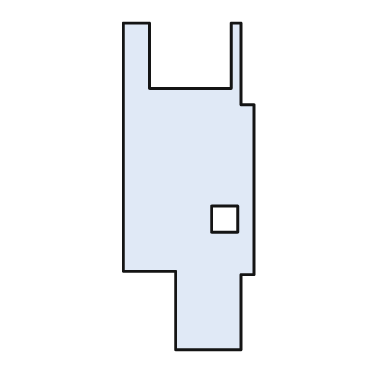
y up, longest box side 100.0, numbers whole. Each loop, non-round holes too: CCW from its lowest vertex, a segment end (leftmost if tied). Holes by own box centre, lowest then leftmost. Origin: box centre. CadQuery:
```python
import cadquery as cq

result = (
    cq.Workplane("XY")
    .moveTo(-4.0, -50.0)
    .lineTo(16.0, -50.0)
    .lineTo(16.0, -27.0)
    .lineTo(20.0, -27.0)
    .lineTo(20.0, 25.0)
    .lineTo(16.0, 25.0)
    .lineTo(16.0, 50.0)
    .lineTo(13.0, 50.0)
    .lineTo(13.0, 30.0)
    .lineTo(-12.0, 30.0)
    .lineTo(-12.0, 50.0)
    .lineTo(-20.0, 50.0)
    .lineTo(-20.0, -26.0)
    .lineTo(-4.0, -26.0)
    .close()
    .moveTo(7.0, -14.0)
    .lineTo(15.0, -14.0)
    .lineTo(15.0, -6.0)
    .lineTo(7.0, -6.0)
    .close()
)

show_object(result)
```